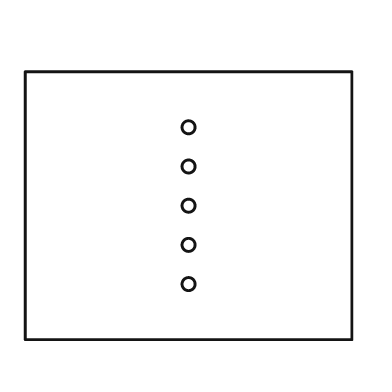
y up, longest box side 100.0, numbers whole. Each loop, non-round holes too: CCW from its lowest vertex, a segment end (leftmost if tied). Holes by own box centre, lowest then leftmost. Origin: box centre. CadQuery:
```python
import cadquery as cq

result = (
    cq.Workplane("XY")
    .moveTo(-50.0, -41.0)
    .lineTo(50.0, -41.0)
    .lineTo(50.0, 41.0)
    .lineTo(-50.0, 41.0)
    .close()
    .moveTo(0.0, -24.0)
    .circle(2.0)
    .moveTo(0.0, -12.0)
    .circle(2.0)
    .moveTo(0.0, 0.0)
    .circle(2.0)
    .moveTo(0.0, 12.0)
    .circle(2.0)
    .moveTo(0.0, 24.0)
    .circle(2.0)
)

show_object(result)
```